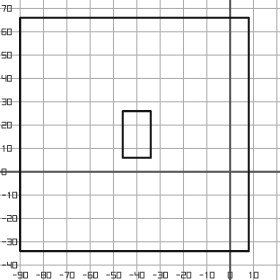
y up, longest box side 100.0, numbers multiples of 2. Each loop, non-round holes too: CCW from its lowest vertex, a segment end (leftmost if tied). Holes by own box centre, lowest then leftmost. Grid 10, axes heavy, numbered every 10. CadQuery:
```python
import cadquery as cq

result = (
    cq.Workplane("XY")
    .moveTo(-90.0, -34.0)
    .lineTo(8.0, -34.0)
    .lineTo(8.0, 66.0)
    .lineTo(-90.0, 66.0)
    .close()
    .moveTo(-46.0, 6.0)
    .lineTo(-34.0, 6.0)
    .lineTo(-34.0, 26.0)
    .lineTo(-46.0, 26.0)
    .close()
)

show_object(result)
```